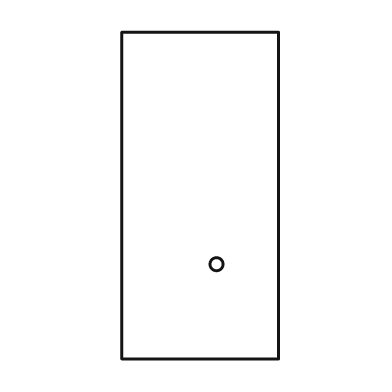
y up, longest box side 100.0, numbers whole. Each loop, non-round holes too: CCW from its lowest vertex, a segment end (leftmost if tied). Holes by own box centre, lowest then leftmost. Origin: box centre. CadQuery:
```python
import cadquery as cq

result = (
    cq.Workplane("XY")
    .moveTo(-24.0, -50.0)
    .lineTo(24.0, -50.0)
    .lineTo(24.0, 50.0)
    .lineTo(-24.0, 50.0)
    .close()
    .moveTo(5.0, -21.0)
    .circle(2.0)
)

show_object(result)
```